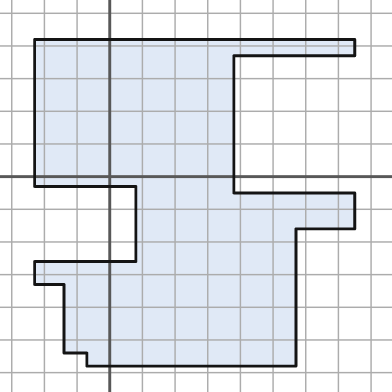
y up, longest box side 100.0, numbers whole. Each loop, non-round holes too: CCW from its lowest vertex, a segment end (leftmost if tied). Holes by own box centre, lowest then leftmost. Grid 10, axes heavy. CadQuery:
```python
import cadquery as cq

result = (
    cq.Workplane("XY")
    .moveTo(-7.0, -58.0)
    .lineTo(57.0, -58.0)
    .lineTo(57.0, -16.0)
    .lineTo(75.0, -16.0)
    .lineTo(75.0, -5.0)
    .lineTo(38.0, -5.0)
    .lineTo(38.0, 37.0)
    .lineTo(75.0, 37.0)
    .lineTo(75.0, 42.0)
    .lineTo(-23.0, 42.0)
    .lineTo(-23.0, -3.0)
    .lineTo(8.0, -3.0)
    .lineTo(8.0, -26.0)
    .lineTo(-23.0, -26.0)
    .lineTo(-23.0, -33.0)
    .lineTo(-14.0, -33.0)
    .lineTo(-14.0, -54.0)
    .lineTo(-7.0, -54.0)
    .close()
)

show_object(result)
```